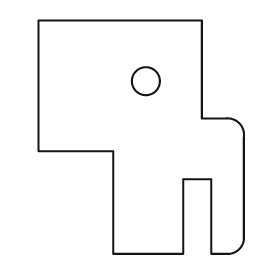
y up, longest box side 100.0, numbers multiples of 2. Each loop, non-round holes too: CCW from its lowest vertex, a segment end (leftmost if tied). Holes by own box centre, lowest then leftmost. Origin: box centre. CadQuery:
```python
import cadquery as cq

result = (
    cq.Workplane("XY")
    .moveTo(-12.0, -50.0)
    .lineTo(18.0, -50.0)
    .lineTo(18.0, -18.0)
    .lineTo(30.0, -18.0)
    .lineTo(30.0, -50.0)
    .lineTo(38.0, -50.0)
    .threePointArc((42.0, -48.0), (44.0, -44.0))
    .lineTo(44.0, 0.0)
    .threePointArc((42.0, 6.0), (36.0, 8.0))
    .lineTo(26.0, 8.0)
    .lineTo(26.0, 50.0)
    .lineTo(-44.0, 50.0)
    .lineTo(-44.0, -6.0)
    .lineTo(-12.0, -6.0)
    .close()
    .moveTo(2.0, 24.0)
    .circle(6.0)
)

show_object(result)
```